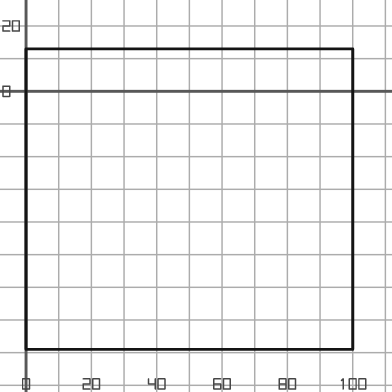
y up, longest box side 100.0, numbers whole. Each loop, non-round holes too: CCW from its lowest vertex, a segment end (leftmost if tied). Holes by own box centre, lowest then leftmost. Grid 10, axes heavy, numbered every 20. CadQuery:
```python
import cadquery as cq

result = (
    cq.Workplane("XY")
    .moveTo(0.0, -79.0)
    .lineTo(100.0, -79.0)
    .lineTo(100.0, 13.0)
    .lineTo(0.0, 13.0)
    .close()
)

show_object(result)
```